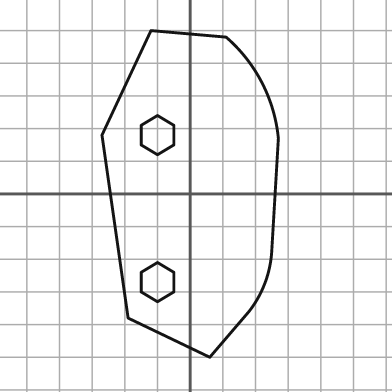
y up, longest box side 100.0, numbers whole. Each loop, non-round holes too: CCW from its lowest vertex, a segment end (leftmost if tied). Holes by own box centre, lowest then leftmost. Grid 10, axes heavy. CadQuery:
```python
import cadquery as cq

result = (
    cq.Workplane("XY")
    .moveTo(6.0, -50.0)
    .lineTo(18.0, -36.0)
    .threePointArc((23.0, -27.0), (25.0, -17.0))
    .lineTo(27.0, 17.0)
    .threePointArc((22.0, 34.0), (11.0, 48.0))
    .lineTo(-12.0, 50.0)
    .lineTo(-27.0, 18.0)
    .lineTo(-19.0, -38.0)
    .close()
    .moveTo(-10.0, -33.0)
    .lineTo(-5.0, -30.0)
    .lineTo(-5.0, -24.0)
    .lineTo(-10.0, -21.0)
    .lineTo(-15.0, -24.0)
    .lineTo(-15.0, -30.0)
    .close()
    .moveTo(-10.0, 12.0)
    .lineTo(-5.0, 15.0)
    .lineTo(-5.0, 21.0)
    .lineTo(-10.0, 24.0)
    .lineTo(-15.0, 21.0)
    .lineTo(-15.0, 15.0)
    .close()
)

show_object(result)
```